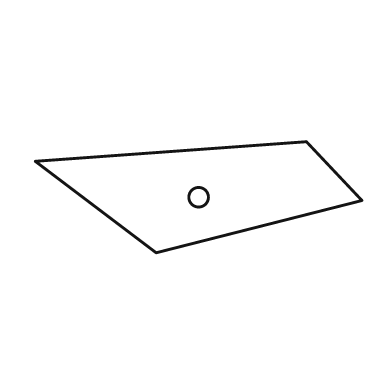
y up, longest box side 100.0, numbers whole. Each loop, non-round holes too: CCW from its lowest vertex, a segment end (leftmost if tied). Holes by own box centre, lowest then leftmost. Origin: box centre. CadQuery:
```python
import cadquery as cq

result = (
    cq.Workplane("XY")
    .moveTo(-13.0, -17.0)
    .lineTo(50.0, -1.0)
    .lineTo(33.0, 17.0)
    .lineTo(-50.0, 11.0)
    .close()
    .moveTo(0.0, 0.0)
    .circle(3.0)
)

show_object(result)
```